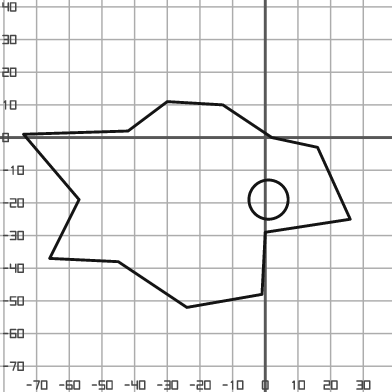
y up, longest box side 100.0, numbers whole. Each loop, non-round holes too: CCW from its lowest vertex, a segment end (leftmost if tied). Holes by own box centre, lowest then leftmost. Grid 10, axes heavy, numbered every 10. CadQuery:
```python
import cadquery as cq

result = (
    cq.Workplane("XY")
    .moveTo(-24.0, -52.0)
    .lineTo(-1.0, -48.0)
    .lineTo(0.0, -29.0)
    .lineTo(26.0, -25.0)
    .lineTo(16.0, -3.0)
    .lineTo(2.0, 0.0)
    .lineTo(-13.0, 10.0)
    .lineTo(-30.0, 11.0)
    .lineTo(-42.0, 2.0)
    .lineTo(-74.0, 1.0)
    .lineTo(-57.0, -19.0)
    .lineTo(-66.0, -37.0)
    .lineTo(-45.0, -38.0)
    .close()
    .moveTo(1.0, -19.0)
    .circle(6.0)
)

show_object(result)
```